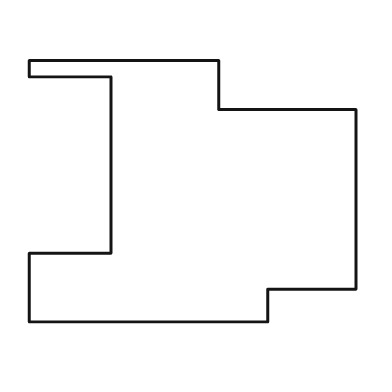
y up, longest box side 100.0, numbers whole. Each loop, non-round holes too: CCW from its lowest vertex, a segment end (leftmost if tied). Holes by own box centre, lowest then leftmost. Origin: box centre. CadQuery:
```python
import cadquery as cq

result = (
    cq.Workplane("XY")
    .moveTo(-50.0, -40.0)
    .lineTo(23.0, -40.0)
    .lineTo(23.0, -30.0)
    .lineTo(50.0, -30.0)
    .lineTo(50.0, 25.0)
    .lineTo(8.0, 25.0)
    .lineTo(8.0, 40.0)
    .lineTo(-50.0, 40.0)
    .lineTo(-50.0, 35.0)
    .lineTo(-25.0, 35.0)
    .lineTo(-25.0, -19.0)
    .lineTo(-50.0, -19.0)
    .close()
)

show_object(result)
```